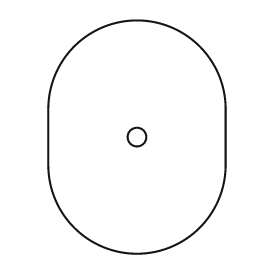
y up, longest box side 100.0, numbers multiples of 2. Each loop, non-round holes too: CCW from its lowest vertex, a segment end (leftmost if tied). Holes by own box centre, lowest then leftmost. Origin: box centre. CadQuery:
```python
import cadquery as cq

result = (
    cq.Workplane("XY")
    .moveTo(-38.0, -12.0)
    .threePointArc((0.0, -50.0), (38.0, -12.0))
    .lineTo(38.0, 12.0)
    .threePointArc((0.0, 50.0), (-38.0, 12.0))
    .close()
    .moveTo(0.0, 0.0)
    .circle(4.0)
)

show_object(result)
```